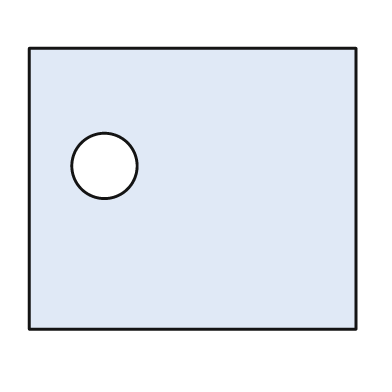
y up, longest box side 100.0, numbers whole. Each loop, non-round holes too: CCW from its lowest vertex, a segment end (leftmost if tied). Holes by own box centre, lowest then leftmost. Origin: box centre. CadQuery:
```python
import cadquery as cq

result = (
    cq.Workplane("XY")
    .moveTo(-50.0, -43.0)
    .lineTo(50.0, -43.0)
    .lineTo(50.0, 43.0)
    .lineTo(-50.0, 43.0)
    .close()
    .moveTo(-27.0, 7.0)
    .circle(10.0)
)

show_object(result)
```